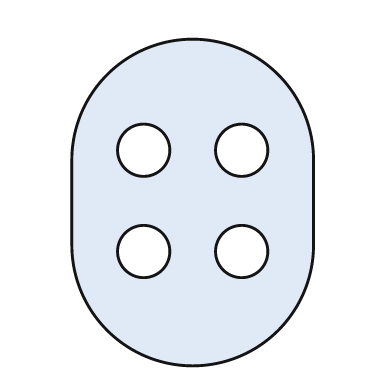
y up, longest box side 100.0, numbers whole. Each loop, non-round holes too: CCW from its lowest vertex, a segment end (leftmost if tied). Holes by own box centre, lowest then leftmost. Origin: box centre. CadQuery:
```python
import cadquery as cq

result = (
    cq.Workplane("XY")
    .moveTo(-37.0, -13.0)
    .threePointArc((0.0, -50.0), (37.0, -13.0))
    .lineTo(37.0, 13.0)
    .threePointArc((0.0, 50.0), (-37.0, 13.0))
    .close()
    .moveTo(-15.0, -15.0)
    .circle(8.0)
    .moveTo(15.0, -15.0)
    .circle(8.0)
    .moveTo(-15.0, 16.0)
    .circle(8.0)
    .moveTo(15.0, 16.0)
    .circle(8.0)
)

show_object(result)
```